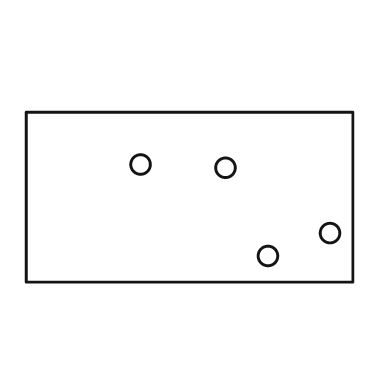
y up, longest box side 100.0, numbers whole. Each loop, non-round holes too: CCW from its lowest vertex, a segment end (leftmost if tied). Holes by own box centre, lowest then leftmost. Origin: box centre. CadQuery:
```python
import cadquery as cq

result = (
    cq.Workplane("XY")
    .moveTo(-50.0, -26.0)
    .lineTo(50.0, -26.0)
    .lineTo(50.0, 26.0)
    .lineTo(-50.0, 26.0)
    .close()
    .moveTo(24.0, -18.0)
    .circle(3.0)
    .moveTo(43.0, -11.0)
    .circle(3.0)
    .moveTo(11.0, 9.0)
    .circle(3.0)
    .moveTo(-15.0, 10.0)
    .circle(3.0)
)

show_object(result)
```